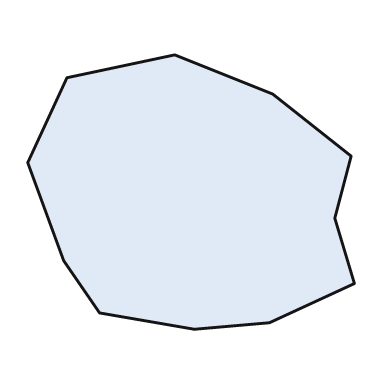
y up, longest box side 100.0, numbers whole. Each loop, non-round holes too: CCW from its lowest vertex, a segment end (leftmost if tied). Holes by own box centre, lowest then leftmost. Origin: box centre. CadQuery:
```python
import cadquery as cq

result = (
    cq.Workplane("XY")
    .moveTo(1.0, -42.0)
    .lineTo(24.0, -40.0)
    .lineTo(50.0, -28.0)
    .lineTo(44.0, -8.0)
    .lineTo(49.0, 11.0)
    .lineTo(25.0, 30.0)
    .lineTo(-5.0, 42.0)
    .lineTo(-38.0, 35.0)
    .lineTo(-50.0, 9.0)
    .lineTo(-39.0, -21.0)
    .lineTo(-28.0, -37.0)
    .close()
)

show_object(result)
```